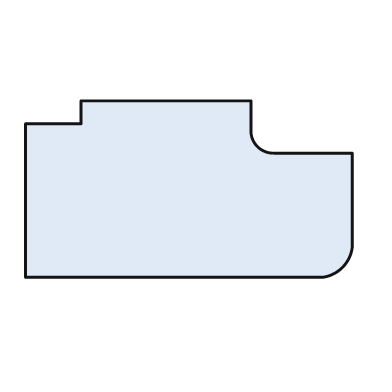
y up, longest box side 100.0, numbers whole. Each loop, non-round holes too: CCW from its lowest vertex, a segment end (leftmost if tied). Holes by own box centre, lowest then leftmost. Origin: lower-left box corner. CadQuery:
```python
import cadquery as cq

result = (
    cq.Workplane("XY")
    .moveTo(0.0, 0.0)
    .lineTo(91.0, 0.0)
    .threePointArc((97.0, 3.0), (100.0, 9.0))
    .lineTo(100.0, 38.0)
    .lineTo(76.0, 38.0)
    .threePointArc((71.0, 40.0), (69.0, 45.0))
    .lineTo(69.0, 54.0)
    .lineTo(17.0, 54.0)
    .lineTo(17.0, 47.0)
    .lineTo(0.0, 47.0)
    .close()
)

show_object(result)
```